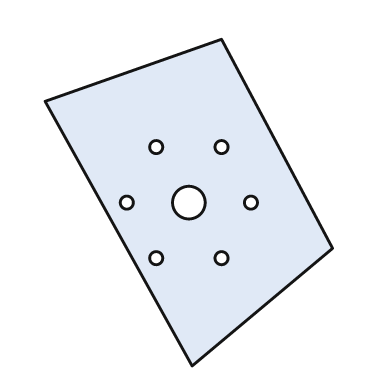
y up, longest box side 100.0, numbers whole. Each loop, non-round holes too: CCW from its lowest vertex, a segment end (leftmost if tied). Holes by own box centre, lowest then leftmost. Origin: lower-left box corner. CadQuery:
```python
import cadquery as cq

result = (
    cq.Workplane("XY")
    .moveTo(45.0, 0.0)
    .lineTo(88.0, 36.0)
    .lineTo(54.0, 100.0)
    .lineTo(0.0, 81.0)
    .close()
    .moveTo(34.0, 33.0)
    .circle(2.0)
    .moveTo(54.0, 33.0)
    .circle(2.0)
    .moveTo(25.0, 50.0)
    .circle(2.0)
    .moveTo(44.0, 50.0)
    .circle(5.0)
    .moveTo(63.0, 50.0)
    .circle(2.0)
    .moveTo(34.0, 67.0)
    .circle(2.0)
    .moveTo(54.0, 67.0)
    .circle(2.0)
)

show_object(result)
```